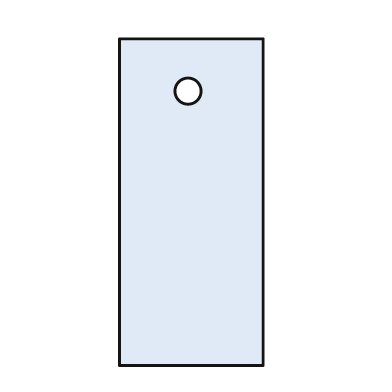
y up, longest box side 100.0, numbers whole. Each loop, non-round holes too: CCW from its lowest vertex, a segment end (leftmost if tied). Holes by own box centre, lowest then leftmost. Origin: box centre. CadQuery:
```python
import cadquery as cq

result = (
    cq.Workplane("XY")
    .moveTo(-22.0, -50.0)
    .lineTo(22.0, -50.0)
    .lineTo(22.0, 50.0)
    .lineTo(-22.0, 50.0)
    .close()
    .moveTo(-1.0, 34.0)
    .circle(4.0)
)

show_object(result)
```